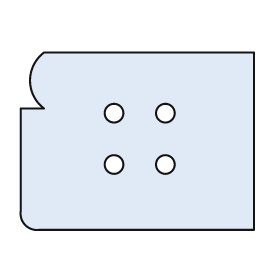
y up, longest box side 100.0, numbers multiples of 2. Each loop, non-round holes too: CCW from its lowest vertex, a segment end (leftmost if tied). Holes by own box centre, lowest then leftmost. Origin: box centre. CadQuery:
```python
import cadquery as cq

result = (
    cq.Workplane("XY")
    .moveTo(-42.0, -38.0)
    .lineTo(50.0, -38.0)
    .lineTo(50.0, 38.0)
    .lineTo(-40.0, 38.0)
    .threePointArc((-46.0, 26.0), (-40.0, 14.0))
    .lineTo(-50.0, 14.0)
    .lineTo(-50.0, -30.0)
    .threePointArc((-48.0, -36.0), (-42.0, -38.0))
    .close()
    .moveTo(-10.0, -10.0)
    .circle(4.0)
    .moveTo(12.0, -10.0)
    .circle(4.0)
    .moveTo(-10.0, 12.0)
    .circle(4.0)
    .moveTo(12.0, 12.0)
    .circle(4.0)
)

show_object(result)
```